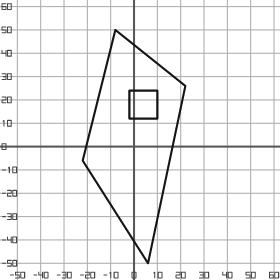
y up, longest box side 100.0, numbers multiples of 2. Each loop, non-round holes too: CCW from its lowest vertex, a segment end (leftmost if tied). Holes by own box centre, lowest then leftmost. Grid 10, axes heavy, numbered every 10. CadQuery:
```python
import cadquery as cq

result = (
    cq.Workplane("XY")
    .moveTo(6.0, -50.0)
    .lineTo(22.0, 26.0)
    .lineTo(-8.0, 50.0)
    .lineTo(-22.0, -6.0)
    .close()
    .moveTo(-2.0, 12.0)
    .lineTo(10.0, 12.0)
    .lineTo(10.0, 24.0)
    .lineTo(-2.0, 24.0)
    .close()
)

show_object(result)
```